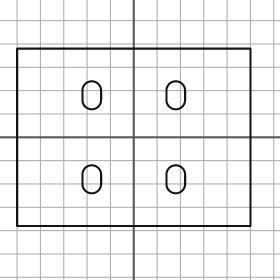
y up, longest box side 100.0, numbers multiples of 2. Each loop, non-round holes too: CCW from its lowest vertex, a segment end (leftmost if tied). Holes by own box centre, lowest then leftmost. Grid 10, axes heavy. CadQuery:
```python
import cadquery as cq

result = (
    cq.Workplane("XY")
    .moveTo(-50.0, -38.0)
    .lineTo(50.0, -38.0)
    .lineTo(50.0, 38.0)
    .lineTo(-50.0, 38.0)
    .close()
    .moveTo(-22.0, -20.0)
    .threePointArc((-18.0, -24.0), (-14.0, -20.0))
    .lineTo(-14.0, -16.0)
    .threePointArc((-18.0, -12.0), (-22.0, -16.0))
    .close()
    .moveTo(14.0, -20.0)
    .threePointArc((18.0, -24.0), (22.0, -20.0))
    .lineTo(22.0, -16.0)
    .threePointArc((18.0, -12.0), (14.0, -16.0))
    .close()
    .moveTo(-22.0, 16.0)
    .threePointArc((-18.0, 12.0), (-14.0, 16.0))
    .lineTo(-14.0, 20.0)
    .threePointArc((-18.0, 24.0), (-22.0, 20.0))
    .close()
    .moveTo(14.0, 16.0)
    .threePointArc((18.0, 12.0), (22.0, 16.0))
    .lineTo(22.0, 20.0)
    .threePointArc((18.0, 24.0), (14.0, 20.0))
    .close()
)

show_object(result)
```